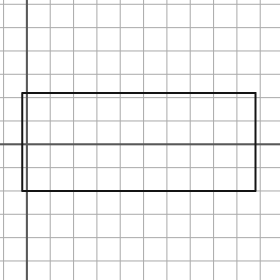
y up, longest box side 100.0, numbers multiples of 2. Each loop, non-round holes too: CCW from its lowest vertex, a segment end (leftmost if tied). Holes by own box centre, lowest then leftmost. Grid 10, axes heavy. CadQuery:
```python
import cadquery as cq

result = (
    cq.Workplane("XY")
    .moveTo(-2.0, -20.0)
    .lineTo(98.0, -20.0)
    .lineTo(98.0, 22.0)
    .lineTo(-2.0, 22.0)
    .close()
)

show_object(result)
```